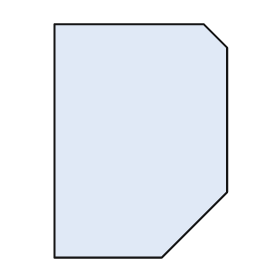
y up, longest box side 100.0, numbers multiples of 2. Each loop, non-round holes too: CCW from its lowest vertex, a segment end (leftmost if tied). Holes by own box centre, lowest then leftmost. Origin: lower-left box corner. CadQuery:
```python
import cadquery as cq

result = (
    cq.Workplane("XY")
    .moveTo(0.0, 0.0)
    .lineTo(46.0, 0.0)
    .lineTo(74.0, 28.0)
    .lineTo(74.0, 90.0)
    .lineTo(64.0, 100.0)
    .lineTo(0.0, 100.0)
    .close()
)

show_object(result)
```